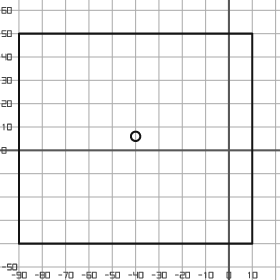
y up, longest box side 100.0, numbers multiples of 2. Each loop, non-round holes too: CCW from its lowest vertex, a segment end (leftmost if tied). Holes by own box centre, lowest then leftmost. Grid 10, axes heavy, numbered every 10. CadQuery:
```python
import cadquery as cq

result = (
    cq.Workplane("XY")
    .moveTo(-90.0, -40.0)
    .lineTo(10.0, -40.0)
    .lineTo(10.0, 50.0)
    .lineTo(-90.0, 50.0)
    .close()
    .moveTo(-40.0, 6.0)
    .circle(2.0)
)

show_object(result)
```